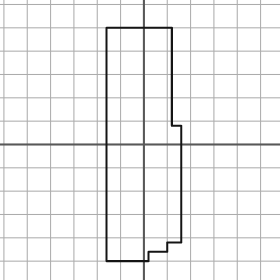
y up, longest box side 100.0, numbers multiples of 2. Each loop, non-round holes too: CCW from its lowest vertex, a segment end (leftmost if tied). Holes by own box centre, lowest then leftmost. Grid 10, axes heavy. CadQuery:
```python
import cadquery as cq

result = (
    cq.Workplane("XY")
    .moveTo(-16.0, -50.0)
    .lineTo(2.0, -50.0)
    .lineTo(2.0, -46.0)
    .lineTo(10.0, -46.0)
    .lineTo(10.0, -42.0)
    .lineTo(16.0, -42.0)
    .lineTo(16.0, 8.0)
    .lineTo(12.0, 8.0)
    .lineTo(12.0, 50.0)
    .lineTo(-16.0, 50.0)
    .close()
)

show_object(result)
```